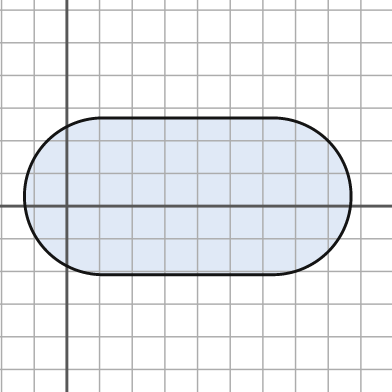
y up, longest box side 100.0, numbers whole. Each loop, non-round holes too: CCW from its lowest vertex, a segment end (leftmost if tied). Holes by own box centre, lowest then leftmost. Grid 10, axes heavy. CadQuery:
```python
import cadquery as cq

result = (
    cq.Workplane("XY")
    .moveTo(11.0, -21.0)
    .lineTo(63.0, -21.0)
    .threePointArc((87.0, 3.0), (63.0, 27.0))
    .lineTo(11.0, 27.0)
    .threePointArc((-13.0, 3.0), (11.0, -21.0))
    .close()
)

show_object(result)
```